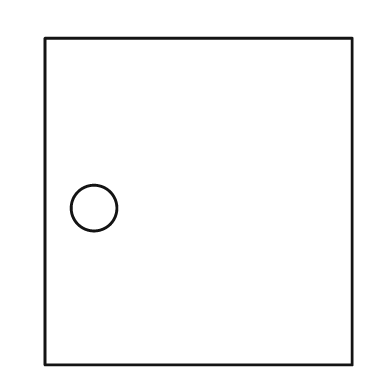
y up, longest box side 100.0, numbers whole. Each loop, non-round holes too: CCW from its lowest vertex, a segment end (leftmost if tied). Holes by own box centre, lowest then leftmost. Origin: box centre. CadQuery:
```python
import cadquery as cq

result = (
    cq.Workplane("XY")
    .moveTo(-47.0, -50.0)
    .lineTo(47.0, -50.0)
    .lineTo(47.0, 50.0)
    .lineTo(-47.0, 50.0)
    .close()
    .moveTo(-32.0, -2.0)
    .circle(7.0)
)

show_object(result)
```